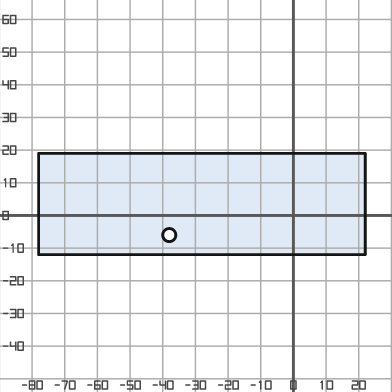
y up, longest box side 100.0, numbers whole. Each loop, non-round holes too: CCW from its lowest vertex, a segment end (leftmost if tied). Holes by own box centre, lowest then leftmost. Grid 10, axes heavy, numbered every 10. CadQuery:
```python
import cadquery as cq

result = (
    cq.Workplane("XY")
    .moveTo(-78.0, -12.0)
    .lineTo(22.0, -12.0)
    .lineTo(22.0, 19.0)
    .lineTo(-78.0, 19.0)
    .close()
    .moveTo(-38.0, -6.0)
    .circle(2.0)
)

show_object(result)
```